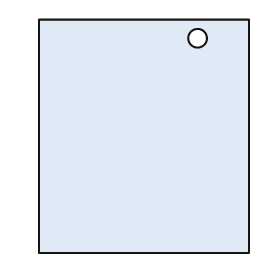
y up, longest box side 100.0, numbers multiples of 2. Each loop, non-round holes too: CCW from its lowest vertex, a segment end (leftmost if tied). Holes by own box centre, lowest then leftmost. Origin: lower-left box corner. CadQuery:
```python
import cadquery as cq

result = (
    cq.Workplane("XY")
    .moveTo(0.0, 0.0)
    .lineTo(90.0, 0.0)
    .lineTo(90.0, 100.0)
    .lineTo(0.0, 100.0)
    .close()
    .moveTo(68.0, 92.0)
    .circle(4.0)
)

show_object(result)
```